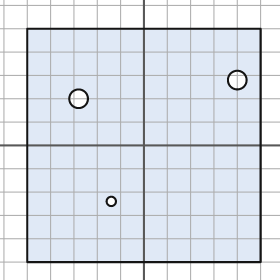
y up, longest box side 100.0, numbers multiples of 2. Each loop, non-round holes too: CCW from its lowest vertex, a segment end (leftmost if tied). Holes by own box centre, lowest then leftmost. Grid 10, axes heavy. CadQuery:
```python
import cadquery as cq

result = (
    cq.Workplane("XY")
    .moveTo(-50.0, -50.0)
    .lineTo(50.0, -50.0)
    .lineTo(50.0, 50.0)
    .lineTo(-50.0, 50.0)
    .close()
    .moveTo(-14.0, -24.0)
    .circle(2.0)
    .moveTo(-28.0, 20.0)
    .circle(4.0)
    .moveTo(40.0, 28.0)
    .circle(4.0)
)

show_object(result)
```